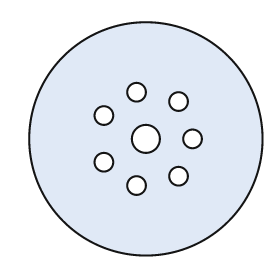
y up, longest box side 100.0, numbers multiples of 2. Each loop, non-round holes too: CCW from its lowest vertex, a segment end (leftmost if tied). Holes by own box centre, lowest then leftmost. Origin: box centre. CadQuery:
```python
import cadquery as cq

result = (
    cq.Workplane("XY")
    .moveTo(0.0, 0.0)
    .circle(50.0)
    .moveTo(-4.0, -20.0)
    .circle(4.0)
    .moveTo(14.0, -16.0)
    .circle(4.0)
    .moveTo(-18.0, -10.0)
    .circle(4.0)
    .moveTo(0.0, 0.0)
    .circle(6.0)
    .moveTo(20.0, 0.0)
    .circle(4.0)
    .moveTo(-18.0, 10.0)
    .circle(4.0)
    .moveTo(14.0, 16.0)
    .circle(4.0)
    .moveTo(-4.0, 20.0)
    .circle(4.0)
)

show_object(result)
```